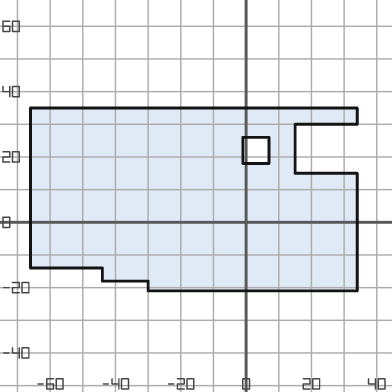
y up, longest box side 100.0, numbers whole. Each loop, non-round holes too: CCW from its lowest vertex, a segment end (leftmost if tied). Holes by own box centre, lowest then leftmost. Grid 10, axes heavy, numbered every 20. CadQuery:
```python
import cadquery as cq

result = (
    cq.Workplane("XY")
    .moveTo(-30.0, -21.0)
    .lineTo(34.0, -21.0)
    .lineTo(34.0, 15.0)
    .lineTo(15.0, 15.0)
    .lineTo(15.0, 30.0)
    .lineTo(34.0, 30.0)
    .lineTo(34.0, 35.0)
    .lineTo(-66.0, 35.0)
    .lineTo(-66.0, -14.0)
    .lineTo(-44.0, -14.0)
    .lineTo(-44.0, -18.0)
    .lineTo(-30.0, -18.0)
    .close()
    .moveTo(-1.0, 18.0)
    .lineTo(7.0, 18.0)
    .lineTo(7.0, 26.0)
    .lineTo(-1.0, 26.0)
    .close()
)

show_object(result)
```